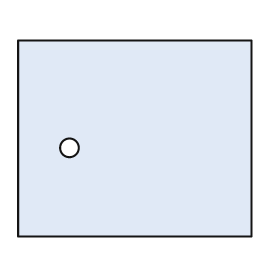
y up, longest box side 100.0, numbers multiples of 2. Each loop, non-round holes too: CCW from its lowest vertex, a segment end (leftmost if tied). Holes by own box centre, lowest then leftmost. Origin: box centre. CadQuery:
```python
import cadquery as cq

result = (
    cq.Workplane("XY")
    .moveTo(-50.0, -42.0)
    .lineTo(50.0, -42.0)
    .lineTo(50.0, 42.0)
    .lineTo(-50.0, 42.0)
    .close()
    .moveTo(-28.0, -4.0)
    .circle(4.0)
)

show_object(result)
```